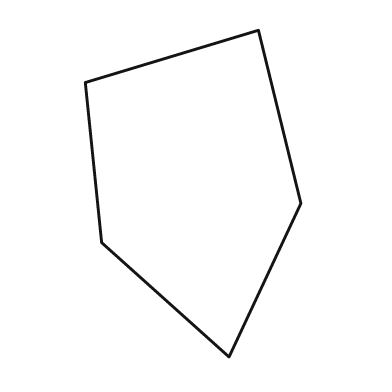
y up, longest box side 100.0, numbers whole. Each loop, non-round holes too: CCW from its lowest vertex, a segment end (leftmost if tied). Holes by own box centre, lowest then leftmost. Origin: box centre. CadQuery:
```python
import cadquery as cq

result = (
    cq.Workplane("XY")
    .moveTo(11.0, -50.0)
    .lineTo(33.0, -3.0)
    .lineTo(20.0, 50.0)
    .lineTo(-33.0, 34.0)
    .lineTo(-28.0, -15.0)
    .close()
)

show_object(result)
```